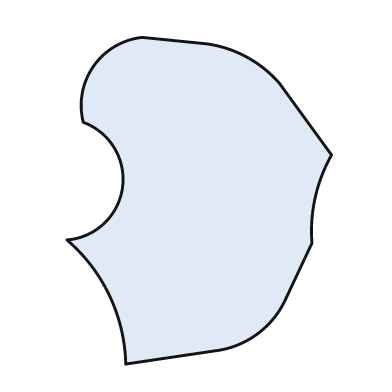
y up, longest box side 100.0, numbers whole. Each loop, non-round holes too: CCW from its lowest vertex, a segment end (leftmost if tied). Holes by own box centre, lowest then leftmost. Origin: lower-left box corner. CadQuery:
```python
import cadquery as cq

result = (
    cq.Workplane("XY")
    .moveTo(18.0, 0.0)
    .lineTo(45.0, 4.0)
    .threePointArc((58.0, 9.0), (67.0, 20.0))
    .lineTo(75.0, 37.0)
    .threePointArc((76.0, 51.0), (81.0, 64.0))
    .lineTo(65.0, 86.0)
    .threePointArc((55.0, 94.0), (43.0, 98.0))
    .lineTo(23.0, 100.0)
    .threePointArc((8.0, 91.0), (5.0, 74.0))
    .threePointArc((17.0, 54.0), (0.0, 38.0))
    .threePointArc((13.0, 21.0), (18.0, 0.0))
    .close()
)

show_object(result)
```